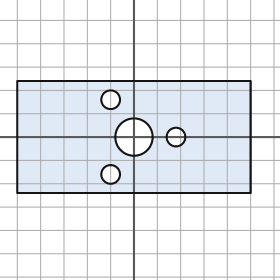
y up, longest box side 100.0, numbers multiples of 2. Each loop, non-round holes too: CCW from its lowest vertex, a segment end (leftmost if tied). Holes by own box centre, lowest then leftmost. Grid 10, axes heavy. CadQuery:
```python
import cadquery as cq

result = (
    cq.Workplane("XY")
    .moveTo(-50.0, -24.0)
    .lineTo(50.0, -24.0)
    .lineTo(50.0, 24.0)
    .lineTo(-50.0, 24.0)
    .close()
    .moveTo(-10.0, -16.0)
    .circle(4.0)
    .moveTo(0.0, 0.0)
    .circle(8.0)
    .moveTo(18.0, 0.0)
    .circle(4.0)
    .moveTo(-10.0, 16.0)
    .circle(4.0)
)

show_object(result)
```